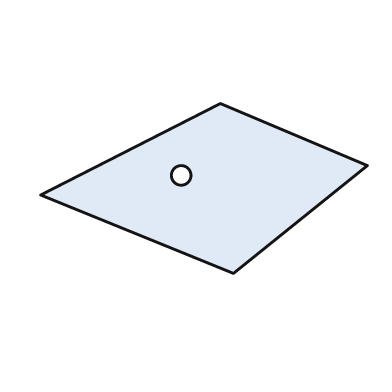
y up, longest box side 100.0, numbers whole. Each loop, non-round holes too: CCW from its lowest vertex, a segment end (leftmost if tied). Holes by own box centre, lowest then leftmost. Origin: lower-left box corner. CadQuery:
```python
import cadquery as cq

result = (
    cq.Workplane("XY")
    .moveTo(59.0, 0.0)
    .lineTo(100.0, 33.0)
    .lineTo(55.0, 52.0)
    .lineTo(0.0, 24.0)
    .close()
    .moveTo(43.0, 30.0)
    .circle(3.0)
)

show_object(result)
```